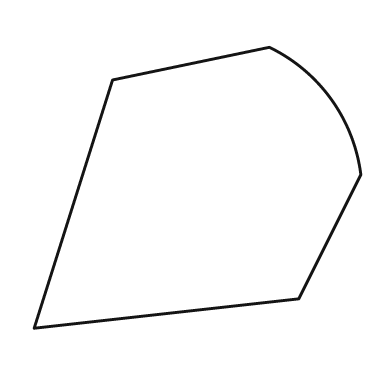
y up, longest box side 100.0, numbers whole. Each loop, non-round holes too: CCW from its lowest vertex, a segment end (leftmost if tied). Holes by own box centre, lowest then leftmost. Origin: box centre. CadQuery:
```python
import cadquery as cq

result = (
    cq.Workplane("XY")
    .moveTo(-50.0, -43.0)
    .lineTo(31.0, -34.0)
    .lineTo(50.0, 4.0)
    .threePointArc((41.0, 27.0), (22.0, 43.0))
    .lineTo(-26.0, 33.0)
    .close()
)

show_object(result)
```